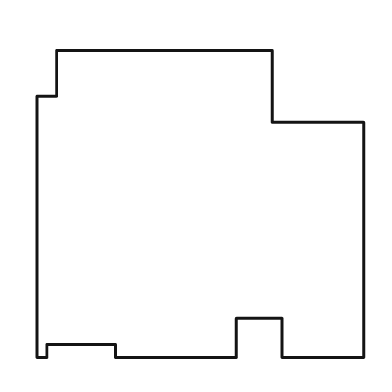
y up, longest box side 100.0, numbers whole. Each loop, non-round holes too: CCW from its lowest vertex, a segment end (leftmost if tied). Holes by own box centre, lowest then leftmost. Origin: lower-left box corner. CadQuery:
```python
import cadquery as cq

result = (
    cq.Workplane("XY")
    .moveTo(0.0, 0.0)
    .lineTo(3.0, 0.0)
    .lineTo(3.0, 4.0)
    .lineTo(24.0, 4.0)
    .lineTo(24.0, 0.0)
    .lineTo(61.0, 0.0)
    .lineTo(61.0, 12.0)
    .lineTo(75.0, 12.0)
    .lineTo(75.0, 0.0)
    .lineTo(100.0, 0.0)
    .lineTo(100.0, 72.0)
    .lineTo(72.0, 72.0)
    .lineTo(72.0, 94.0)
    .lineTo(6.0, 94.0)
    .lineTo(6.0, 80.0)
    .lineTo(0.0, 80.0)
    .close()
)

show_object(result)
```